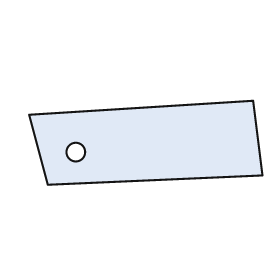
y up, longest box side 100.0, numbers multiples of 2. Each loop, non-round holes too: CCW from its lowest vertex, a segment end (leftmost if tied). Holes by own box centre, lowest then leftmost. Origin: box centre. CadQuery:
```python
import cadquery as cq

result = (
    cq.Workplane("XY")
    .moveTo(-42.0, -18.0)
    .lineTo(50.0, -14.0)
    .lineTo(46.0, 18.0)
    .lineTo(-50.0, 12.0)
    .close()
    .moveTo(-30.0, -4.0)
    .circle(4.0)
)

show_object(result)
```